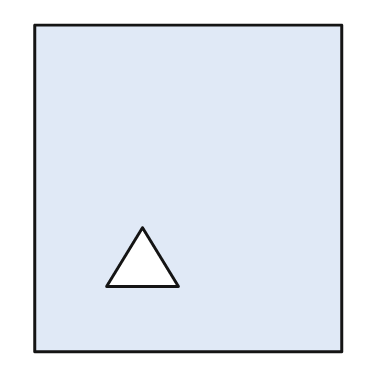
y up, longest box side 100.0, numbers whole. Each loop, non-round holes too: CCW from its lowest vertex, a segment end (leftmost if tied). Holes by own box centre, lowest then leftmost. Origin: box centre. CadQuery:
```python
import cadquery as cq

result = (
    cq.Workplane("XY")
    .moveTo(-47.0, -50.0)
    .lineTo(47.0, -50.0)
    .lineTo(47.0, 50.0)
    .lineTo(-47.0, 50.0)
    .close()
    .moveTo(-25.0, -30.0)
    .lineTo(-3.0, -30.0)
    .lineTo(-14.0, -12.0)
    .close()
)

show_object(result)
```